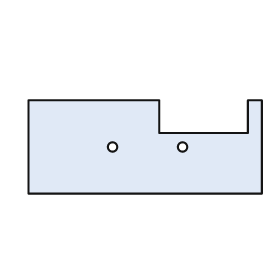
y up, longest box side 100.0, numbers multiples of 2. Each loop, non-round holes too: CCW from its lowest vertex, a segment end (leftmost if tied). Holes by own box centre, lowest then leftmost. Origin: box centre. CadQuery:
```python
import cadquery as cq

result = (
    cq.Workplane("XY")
    .moveTo(-50.0, -20.0)
    .lineTo(50.0, -20.0)
    .lineTo(50.0, 20.0)
    .lineTo(44.0, 20.0)
    .lineTo(44.0, 6.0)
    .lineTo(6.0, 6.0)
    .lineTo(6.0, 20.0)
    .lineTo(-50.0, 20.0)
    .close()
    .moveTo(-14.0, 0.0)
    .circle(2.0)
    .moveTo(16.0, 0.0)
    .circle(2.0)
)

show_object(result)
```